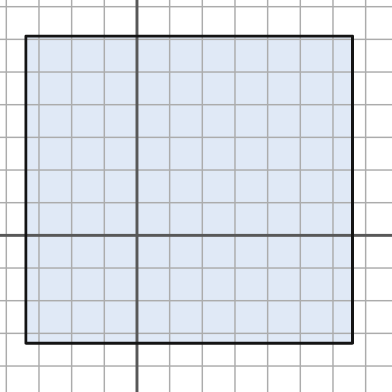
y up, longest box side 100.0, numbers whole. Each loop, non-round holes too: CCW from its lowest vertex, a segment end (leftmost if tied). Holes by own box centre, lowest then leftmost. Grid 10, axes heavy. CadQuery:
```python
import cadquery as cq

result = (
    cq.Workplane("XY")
    .moveTo(-34.0, -33.0)
    .lineTo(66.0, -33.0)
    .lineTo(66.0, 61.0)
    .lineTo(-34.0, 61.0)
    .close()
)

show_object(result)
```